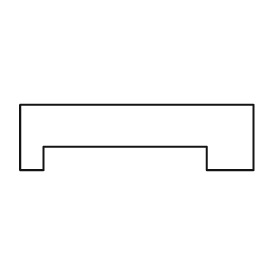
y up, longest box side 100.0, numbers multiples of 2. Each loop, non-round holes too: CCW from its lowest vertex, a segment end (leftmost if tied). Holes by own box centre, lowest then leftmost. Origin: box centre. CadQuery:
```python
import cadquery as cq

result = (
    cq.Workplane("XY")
    .moveTo(-50.0, -14.0)
    .lineTo(-40.0, -14.0)
    .lineTo(-40.0, -4.0)
    .lineTo(30.0, -4.0)
    .lineTo(30.0, -14.0)
    .lineTo(50.0, -14.0)
    .lineTo(50.0, 14.0)
    .lineTo(-50.0, 14.0)
    .close()
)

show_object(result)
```